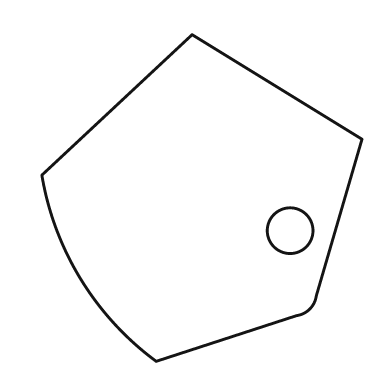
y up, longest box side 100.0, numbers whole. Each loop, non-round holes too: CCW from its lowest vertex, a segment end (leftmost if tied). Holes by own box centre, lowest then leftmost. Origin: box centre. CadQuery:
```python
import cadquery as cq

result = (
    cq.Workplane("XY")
    .moveTo(-14.0, -50.0)
    .lineTo(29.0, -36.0)
    .threePointArc((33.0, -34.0), (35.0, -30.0))
    .lineTo(49.0, 18.0)
    .lineTo(-3.0, 50.0)
    .lineTo(-49.0, 7.0)
    .threePointArc((-37.0, -25.0), (-14.0, -50.0))
    .close()
    .moveTo(27.0, -10.0)
    .circle(7.0)
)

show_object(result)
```